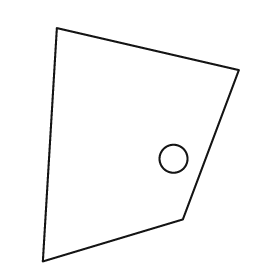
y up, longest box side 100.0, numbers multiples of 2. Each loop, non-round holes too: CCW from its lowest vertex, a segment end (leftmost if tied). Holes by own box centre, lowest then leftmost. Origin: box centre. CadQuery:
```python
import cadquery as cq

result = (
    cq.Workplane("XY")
    .moveTo(-42.0, -50.0)
    .lineTo(18.0, -32.0)
    .lineTo(42.0, 32.0)
    .lineTo(-36.0, 50.0)
    .close()
    .moveTo(14.0, -6.0)
    .circle(6.0)
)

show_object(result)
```